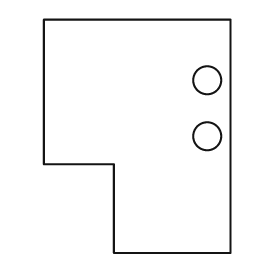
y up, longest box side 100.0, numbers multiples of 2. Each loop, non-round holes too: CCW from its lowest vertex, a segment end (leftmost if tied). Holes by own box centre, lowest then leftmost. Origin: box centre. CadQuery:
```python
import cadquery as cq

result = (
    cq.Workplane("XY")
    .moveTo(-10.0, -50.0)
    .lineTo(40.0, -50.0)
    .lineTo(40.0, 50.0)
    .lineTo(-40.0, 50.0)
    .lineTo(-40.0, -12.0)
    .lineTo(-10.0, -12.0)
    .close()
    .moveTo(30.0, 0.0)
    .circle(6.0)
    .moveTo(30.0, 24.0)
    .circle(6.0)
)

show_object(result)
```